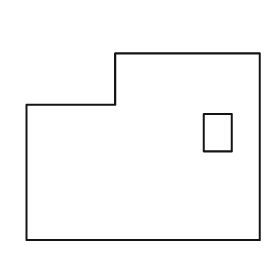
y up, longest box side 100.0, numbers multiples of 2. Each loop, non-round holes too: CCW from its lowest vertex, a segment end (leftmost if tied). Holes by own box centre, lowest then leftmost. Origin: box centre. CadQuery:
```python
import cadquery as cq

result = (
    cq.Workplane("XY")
    .moveTo(-50.0, -40.0)
    .lineTo(50.0, -40.0)
    .lineTo(50.0, 40.0)
    .lineTo(-12.0, 40.0)
    .lineTo(-12.0, 18.0)
    .lineTo(-50.0, 18.0)
    .close()
    .moveTo(26.0, -2.0)
    .lineTo(38.0, -2.0)
    .lineTo(38.0, 14.0)
    .lineTo(26.0, 14.0)
    .close()
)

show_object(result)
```